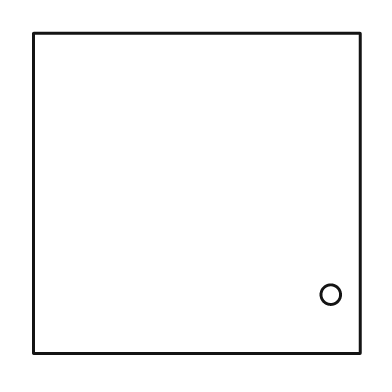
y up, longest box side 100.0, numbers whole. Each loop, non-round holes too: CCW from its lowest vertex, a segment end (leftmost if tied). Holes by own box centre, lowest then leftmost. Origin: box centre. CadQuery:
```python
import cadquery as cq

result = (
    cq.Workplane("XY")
    .moveTo(-50.0, -49.0)
    .lineTo(50.0, -49.0)
    .lineTo(50.0, 49.0)
    .lineTo(-50.0, 49.0)
    .close()
    .moveTo(41.0, -31.0)
    .circle(3.0)
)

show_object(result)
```